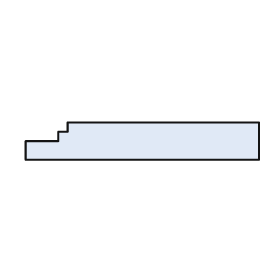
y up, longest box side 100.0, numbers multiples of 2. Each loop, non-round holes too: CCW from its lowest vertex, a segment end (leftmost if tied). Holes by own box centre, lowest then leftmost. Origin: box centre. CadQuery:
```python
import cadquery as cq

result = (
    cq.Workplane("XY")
    .moveTo(-50.0, -8.0)
    .lineTo(50.0, -8.0)
    .lineTo(50.0, 8.0)
    .lineTo(-32.0, 8.0)
    .lineTo(-32.0, 4.0)
    .lineTo(-36.0, 4.0)
    .lineTo(-36.0, 0.0)
    .lineTo(-50.0, 0.0)
    .close()
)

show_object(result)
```